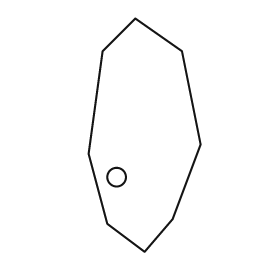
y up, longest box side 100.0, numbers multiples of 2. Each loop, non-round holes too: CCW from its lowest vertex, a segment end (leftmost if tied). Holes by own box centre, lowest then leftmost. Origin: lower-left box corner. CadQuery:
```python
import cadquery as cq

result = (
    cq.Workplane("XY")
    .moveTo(24.0, 0.0)
    .lineTo(36.0, 14.0)
    .lineTo(48.0, 46.0)
    .lineTo(40.0, 86.0)
    .lineTo(20.0, 100.0)
    .lineTo(6.0, 86.0)
    .lineTo(0.0, 42.0)
    .lineTo(8.0, 12.0)
    .close()
    .moveTo(12.0, 32.0)
    .circle(4.0)
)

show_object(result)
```